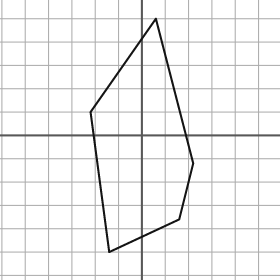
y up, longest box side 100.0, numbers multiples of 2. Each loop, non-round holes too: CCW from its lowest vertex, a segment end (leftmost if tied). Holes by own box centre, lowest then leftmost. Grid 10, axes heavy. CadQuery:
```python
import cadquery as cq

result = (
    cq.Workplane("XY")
    .moveTo(-14.0, -50.0)
    .lineTo(16.0, -36.0)
    .lineTo(22.0, -12.0)
    .lineTo(6.0, 50.0)
    .lineTo(-22.0, 10.0)
    .close()
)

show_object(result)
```